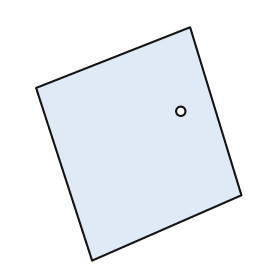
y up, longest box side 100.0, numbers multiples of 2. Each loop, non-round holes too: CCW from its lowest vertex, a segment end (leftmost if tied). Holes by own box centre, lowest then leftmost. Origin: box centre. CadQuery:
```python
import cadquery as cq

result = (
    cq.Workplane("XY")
    .moveTo(-20.0, -50.0)
    .lineTo(44.0, -22.0)
    .lineTo(22.0, 50.0)
    .lineTo(-44.0, 24.0)
    .close()
    .moveTo(18.0, 14.0)
    .circle(2.0)
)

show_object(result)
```